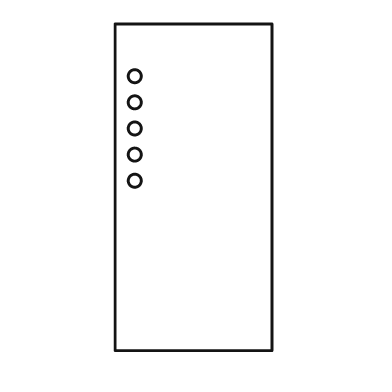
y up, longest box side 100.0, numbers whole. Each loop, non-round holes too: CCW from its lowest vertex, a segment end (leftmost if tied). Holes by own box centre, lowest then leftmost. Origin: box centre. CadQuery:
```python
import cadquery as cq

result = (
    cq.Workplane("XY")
    .moveTo(-24.0, -50.0)
    .lineTo(24.0, -50.0)
    .lineTo(24.0, 50.0)
    .lineTo(-24.0, 50.0)
    .close()
    .moveTo(-18.0, 2.0)
    .circle(2.0)
    .moveTo(-18.0, 10.0)
    .circle(2.0)
    .moveTo(-18.0, 18.0)
    .circle(2.0)
    .moveTo(-18.0, 26.0)
    .circle(2.0)
    .moveTo(-18.0, 34.0)
    .circle(2.0)
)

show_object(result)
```